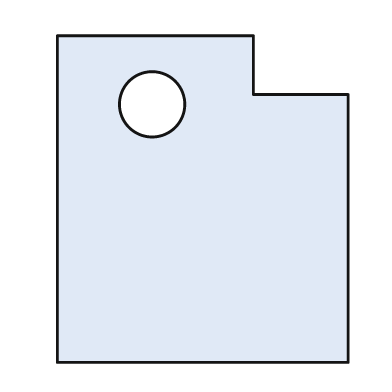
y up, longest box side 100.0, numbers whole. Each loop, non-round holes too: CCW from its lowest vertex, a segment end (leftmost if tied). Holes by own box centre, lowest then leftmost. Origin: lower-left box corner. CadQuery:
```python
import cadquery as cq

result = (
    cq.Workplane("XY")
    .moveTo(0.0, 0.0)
    .lineTo(89.0, 0.0)
    .lineTo(89.0, 82.0)
    .lineTo(60.0, 82.0)
    .lineTo(60.0, 100.0)
    .lineTo(0.0, 100.0)
    .close()
    .moveTo(29.0, 79.0)
    .circle(10.0)
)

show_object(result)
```